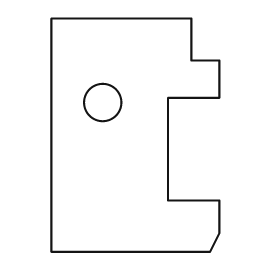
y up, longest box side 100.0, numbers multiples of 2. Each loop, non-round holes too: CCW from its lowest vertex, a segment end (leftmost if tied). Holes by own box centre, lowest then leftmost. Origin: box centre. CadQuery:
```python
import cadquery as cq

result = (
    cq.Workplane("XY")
    .moveTo(-36.0, -50.0)
    .lineTo(32.0, -50.0)
    .lineTo(36.0, -42.0)
    .lineTo(36.0, -28.0)
    .lineTo(14.0, -28.0)
    .lineTo(14.0, 16.0)
    .lineTo(36.0, 16.0)
    .lineTo(36.0, 32.0)
    .lineTo(24.0, 32.0)
    .lineTo(24.0, 50.0)
    .lineTo(-36.0, 50.0)
    .close()
    .moveTo(-14.0, 14.0)
    .circle(8.0)
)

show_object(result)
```